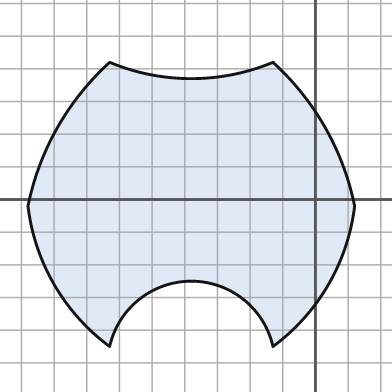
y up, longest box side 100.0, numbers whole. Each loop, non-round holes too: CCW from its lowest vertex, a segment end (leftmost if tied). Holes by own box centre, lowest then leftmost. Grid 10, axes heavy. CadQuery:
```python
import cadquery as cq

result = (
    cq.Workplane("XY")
    .moveTo(-63.0, -45.0)
    .threePointArc((-38.0, -25.0), (-13.0, -45.0))
    .threePointArc((4.0, -26.0), (12.0, -2.0))
    .threePointArc((3.0, 22.0), (-13.0, 42.0))
    .threePointArc((-38.0, 37.0), (-63.0, 42.0))
    .threePointArc((-79.0, 22.0), (-88.0, -2.0))
    .threePointArc((-80.0, -26.0), (-63.0, -45.0))
    .close()
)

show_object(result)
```